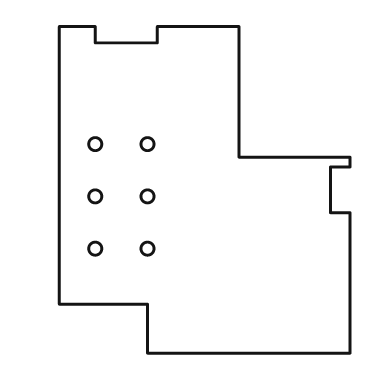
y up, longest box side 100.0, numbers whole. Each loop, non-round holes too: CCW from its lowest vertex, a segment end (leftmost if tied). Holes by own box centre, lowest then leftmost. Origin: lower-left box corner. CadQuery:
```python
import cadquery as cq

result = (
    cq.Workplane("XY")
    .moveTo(27.0, 0.0)
    .lineTo(89.0, 0.0)
    .lineTo(89.0, 43.0)
    .lineTo(83.0, 43.0)
    .lineTo(83.0, 57.0)
    .lineTo(89.0, 57.0)
    .lineTo(89.0, 60.0)
    .lineTo(55.0, 60.0)
    .lineTo(55.0, 100.0)
    .lineTo(30.0, 100.0)
    .lineTo(30.0, 95.0)
    .lineTo(11.0, 95.0)
    .lineTo(11.0, 100.0)
    .lineTo(0.0, 100.0)
    .lineTo(0.0, 15.0)
    .lineTo(27.0, 15.0)
    .close()
    .moveTo(11.0, 32.0)
    .circle(2.0)
    .moveTo(27.0, 32.0)
    .circle(2.0)
    .moveTo(11.0, 48.0)
    .circle(2.0)
    .moveTo(27.0, 48.0)
    .circle(2.0)
    .moveTo(11.0, 64.0)
    .circle(2.0)
    .moveTo(27.0, 64.0)
    .circle(2.0)
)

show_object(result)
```